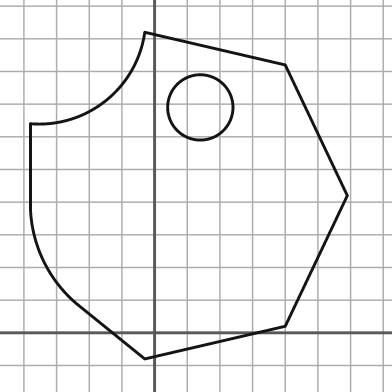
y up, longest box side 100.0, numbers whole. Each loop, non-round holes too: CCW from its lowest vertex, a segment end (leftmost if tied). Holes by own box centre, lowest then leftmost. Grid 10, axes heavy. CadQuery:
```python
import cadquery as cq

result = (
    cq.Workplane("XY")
    .moveTo(-3.0, -8.0)
    .lineTo(40.0, 2.0)
    .lineTo(59.0, 42.0)
    .lineTo(40.0, 82.0)
    .lineTo(-3.0, 92.0)
    .threePointArc((-15.0, 71.0), (-38.0, 64.0))
    .lineTo(-38.0, 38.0)
    .threePointArc((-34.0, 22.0), (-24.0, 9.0))
    .close()
    .moveTo(14.0, 69.0)
    .circle(10.0)
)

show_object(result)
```